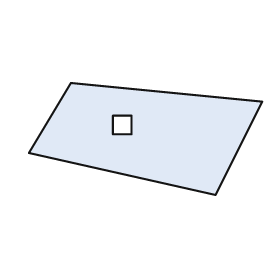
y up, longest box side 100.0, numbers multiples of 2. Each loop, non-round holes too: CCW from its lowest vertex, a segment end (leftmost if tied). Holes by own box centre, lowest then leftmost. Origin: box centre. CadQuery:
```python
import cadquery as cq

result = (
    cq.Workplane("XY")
    .moveTo(30.0, -24.0)
    .lineTo(50.0, 16.0)
    .lineTo(-32.0, 24.0)
    .lineTo(-50.0, -6.0)
    .close()
    .moveTo(-14.0, 2.0)
    .lineTo(-6.0, 2.0)
    .lineTo(-6.0, 10.0)
    .lineTo(-14.0, 10.0)
    .close()
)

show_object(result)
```